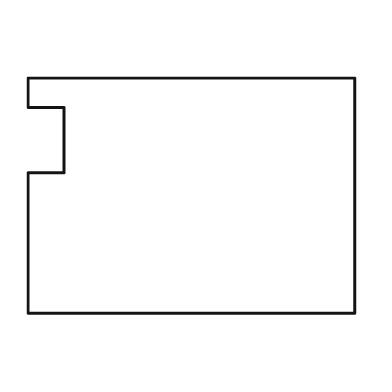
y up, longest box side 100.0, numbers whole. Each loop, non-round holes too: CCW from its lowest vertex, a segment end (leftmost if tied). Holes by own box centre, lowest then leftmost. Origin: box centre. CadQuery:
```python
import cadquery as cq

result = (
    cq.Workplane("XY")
    .moveTo(-50.0, -36.0)
    .lineTo(50.0, -36.0)
    .lineTo(50.0, 36.0)
    .lineTo(-50.0, 36.0)
    .lineTo(-50.0, 27.0)
    .lineTo(-39.0, 27.0)
    .lineTo(-39.0, 7.0)
    .lineTo(-50.0, 7.0)
    .close()
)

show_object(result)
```